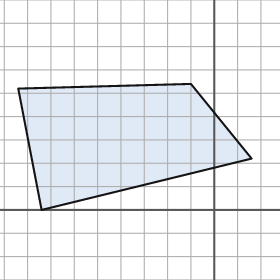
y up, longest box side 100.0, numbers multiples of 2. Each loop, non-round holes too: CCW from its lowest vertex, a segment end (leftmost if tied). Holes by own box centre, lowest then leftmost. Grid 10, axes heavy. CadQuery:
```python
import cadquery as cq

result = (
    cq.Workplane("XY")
    .moveTo(-74.0, 0.0)
    .lineTo(16.0, 22.0)
    .lineTo(-10.0, 54.0)
    .lineTo(-84.0, 52.0)
    .close()
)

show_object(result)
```